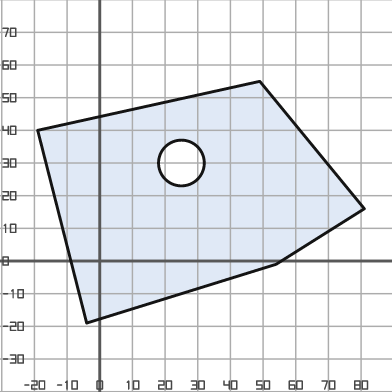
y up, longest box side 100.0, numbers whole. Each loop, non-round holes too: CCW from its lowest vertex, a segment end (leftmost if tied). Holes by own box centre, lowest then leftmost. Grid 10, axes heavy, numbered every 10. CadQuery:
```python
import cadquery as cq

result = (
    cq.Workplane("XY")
    .moveTo(-4.0, -19.0)
    .lineTo(54.0, -1.0)
    .lineTo(81.0, 16.0)
    .lineTo(49.0, 55.0)
    .lineTo(-19.0, 40.0)
    .close()
    .moveTo(25.0, 30.0)
    .circle(7.0)
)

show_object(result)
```